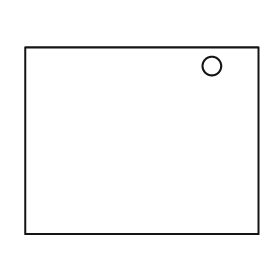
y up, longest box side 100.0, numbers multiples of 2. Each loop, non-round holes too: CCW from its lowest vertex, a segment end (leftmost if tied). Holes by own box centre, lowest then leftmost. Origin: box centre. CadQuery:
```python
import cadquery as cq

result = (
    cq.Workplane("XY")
    .moveTo(-50.0, -40.0)
    .lineTo(50.0, -40.0)
    .lineTo(50.0, 40.0)
    .lineTo(-50.0, 40.0)
    .close()
    .moveTo(30.0, 32.0)
    .circle(4.0)
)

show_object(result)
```